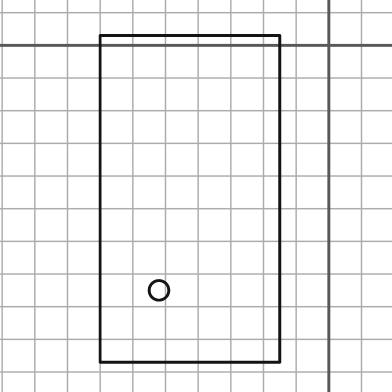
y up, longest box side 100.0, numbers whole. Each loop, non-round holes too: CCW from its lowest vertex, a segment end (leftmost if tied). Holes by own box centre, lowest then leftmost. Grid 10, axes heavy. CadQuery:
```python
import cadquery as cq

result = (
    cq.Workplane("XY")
    .moveTo(-70.0, -97.0)
    .lineTo(-15.0, -97.0)
    .lineTo(-15.0, 3.0)
    .lineTo(-70.0, 3.0)
    .close()
    .moveTo(-52.0, -75.0)
    .circle(3.0)
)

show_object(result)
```